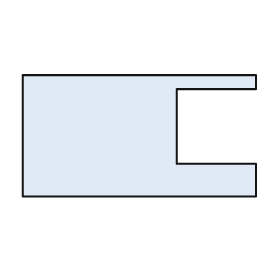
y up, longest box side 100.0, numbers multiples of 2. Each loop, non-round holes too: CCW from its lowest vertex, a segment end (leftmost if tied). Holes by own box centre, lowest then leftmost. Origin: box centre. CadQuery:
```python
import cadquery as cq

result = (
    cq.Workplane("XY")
    .moveTo(-50.0, -26.0)
    .lineTo(50.0, -26.0)
    .lineTo(50.0, -12.0)
    .lineTo(16.0, -12.0)
    .lineTo(16.0, 20.0)
    .lineTo(50.0, 20.0)
    .lineTo(50.0, 26.0)
    .lineTo(-50.0, 26.0)
    .close()
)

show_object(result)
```